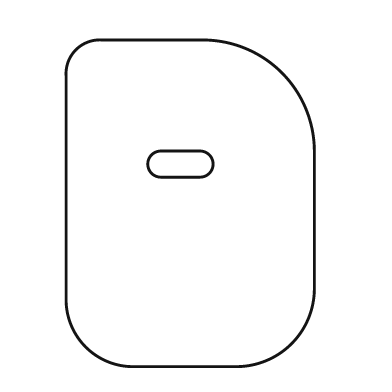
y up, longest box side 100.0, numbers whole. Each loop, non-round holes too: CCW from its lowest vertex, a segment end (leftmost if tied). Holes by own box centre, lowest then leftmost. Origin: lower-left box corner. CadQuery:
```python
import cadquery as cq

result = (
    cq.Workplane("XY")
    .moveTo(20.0, 0.0)
    .lineTo(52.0, 0.0)
    .threePointArc((69.0, 7.0), (76.0, 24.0))
    .lineTo(76.0, 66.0)
    .threePointArc((66.0, 90.0), (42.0, 100.0))
    .lineTo(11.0, 100.0)
    .threePointArc((3.0, 97.0), (0.0, 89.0))
    .lineTo(0.0, 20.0)
    .threePointArc((6.0, 6.0), (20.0, 0.0))
    .close()
    .moveTo(29.0, 58.0)
    .lineTo(41.0, 58.0)
    .threePointArc((45.0, 62.0), (41.0, 66.0))
    .lineTo(29.0, 66.0)
    .threePointArc((25.0, 62.0), (29.0, 58.0))
    .close()
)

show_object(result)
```